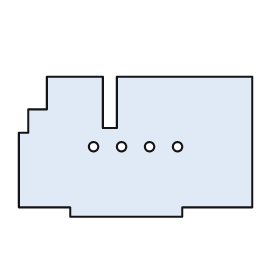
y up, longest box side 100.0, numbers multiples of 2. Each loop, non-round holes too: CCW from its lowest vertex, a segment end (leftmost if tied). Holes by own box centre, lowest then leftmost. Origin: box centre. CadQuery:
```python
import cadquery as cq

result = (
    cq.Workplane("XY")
    .moveTo(-28.0, -30.0)
    .lineTo(20.0, -30.0)
    .lineTo(20.0, -26.0)
    .lineTo(50.0, -26.0)
    .lineTo(50.0, 30.0)
    .lineTo(-8.0, 30.0)
    .lineTo(-8.0, 8.0)
    .lineTo(-14.0, 8.0)
    .lineTo(-14.0, 30.0)
    .lineTo(-38.0, 30.0)
    .lineTo(-38.0, 16.0)
    .lineTo(-46.0, 16.0)
    .lineTo(-46.0, 6.0)
    .lineTo(-50.0, 6.0)
    .lineTo(-50.0, -26.0)
    .lineTo(-28.0, -26.0)
    .close()
    .moveTo(-18.0, 0.0)
    .circle(2.0)
    .moveTo(-6.0, 0.0)
    .circle(2.0)
    .moveTo(6.0, 0.0)
    .circle(2.0)
    .moveTo(18.0, 0.0)
    .circle(2.0)
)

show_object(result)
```